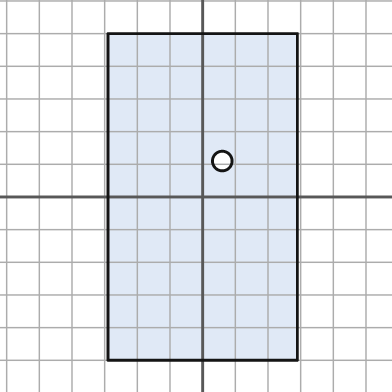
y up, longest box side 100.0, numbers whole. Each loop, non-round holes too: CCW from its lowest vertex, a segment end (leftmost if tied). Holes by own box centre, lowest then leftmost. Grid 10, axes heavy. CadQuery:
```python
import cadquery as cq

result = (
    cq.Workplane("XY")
    .moveTo(-29.0, -50.0)
    .lineTo(29.0, -50.0)
    .lineTo(29.0, 50.0)
    .lineTo(-29.0, 50.0)
    .close()
    .moveTo(6.0, 11.0)
    .circle(3.0)
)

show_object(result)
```